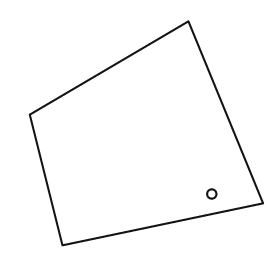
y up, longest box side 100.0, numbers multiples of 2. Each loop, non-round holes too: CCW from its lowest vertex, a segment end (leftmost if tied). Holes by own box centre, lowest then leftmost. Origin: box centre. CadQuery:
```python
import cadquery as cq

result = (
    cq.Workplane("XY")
    .moveTo(-36.0, -48.0)
    .lineTo(50.0, -30.0)
    .lineTo(18.0, 48.0)
    .lineTo(-50.0, 8.0)
    .close()
    .moveTo(28.0, -26.0)
    .circle(2.0)
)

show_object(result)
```